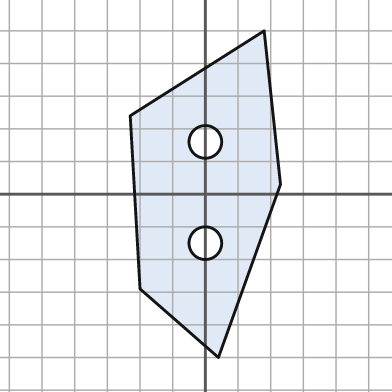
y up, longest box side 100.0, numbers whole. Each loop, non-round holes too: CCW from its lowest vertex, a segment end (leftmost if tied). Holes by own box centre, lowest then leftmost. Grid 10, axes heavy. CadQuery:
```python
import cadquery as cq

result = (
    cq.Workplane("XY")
    .moveTo(4.0, -50.0)
    .lineTo(23.0, 3.0)
    .lineTo(18.0, 50.0)
    .lineTo(-23.0, 24.0)
    .lineTo(-20.0, -29.0)
    .close()
    .moveTo(0.0, -15.0)
    .circle(5.0)
    .moveTo(0.0, 16.0)
    .circle(5.0)
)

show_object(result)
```